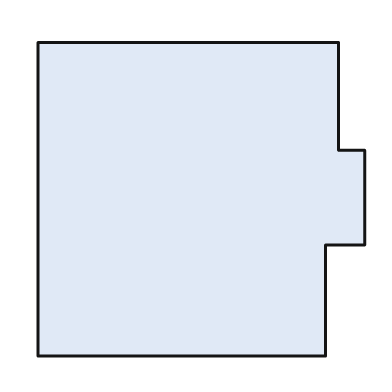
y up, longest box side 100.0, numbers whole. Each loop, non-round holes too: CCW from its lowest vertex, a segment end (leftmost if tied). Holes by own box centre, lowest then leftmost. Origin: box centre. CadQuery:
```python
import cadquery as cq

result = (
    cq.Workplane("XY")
    .moveTo(-50.0, -48.0)
    .lineTo(38.0, -48.0)
    .lineTo(38.0, -14.0)
    .lineTo(50.0, -14.0)
    .lineTo(50.0, 15.0)
    .lineTo(42.0, 15.0)
    .lineTo(42.0, 48.0)
    .lineTo(-50.0, 48.0)
    .close()
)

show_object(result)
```